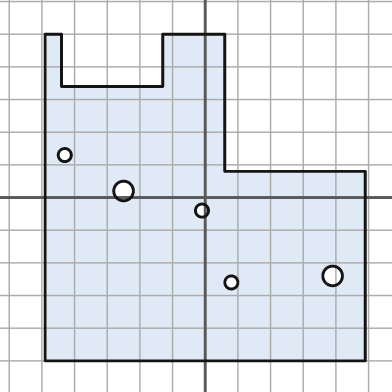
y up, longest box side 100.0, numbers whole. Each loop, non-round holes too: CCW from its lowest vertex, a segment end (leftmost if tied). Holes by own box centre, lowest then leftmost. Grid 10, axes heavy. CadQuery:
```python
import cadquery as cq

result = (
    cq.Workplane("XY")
    .moveTo(-49.0, -50.0)
    .lineTo(49.0, -50.0)
    .lineTo(49.0, 8.0)
    .lineTo(6.0, 8.0)
    .lineTo(6.0, 50.0)
    .lineTo(-13.0, 50.0)
    .lineTo(-13.0, 34.0)
    .lineTo(-44.0, 34.0)
    .lineTo(-44.0, 50.0)
    .lineTo(-49.0, 50.0)
    .close()
    .moveTo(8.0, -26.0)
    .circle(2.0)
    .moveTo(39.0, -24.0)
    .circle(3.0)
    .moveTo(-1.0, -4.0)
    .circle(2.0)
    .moveTo(-25.0, 2.0)
    .circle(3.0)
    .moveTo(-43.0, 13.0)
    .circle(2.0)
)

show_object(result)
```